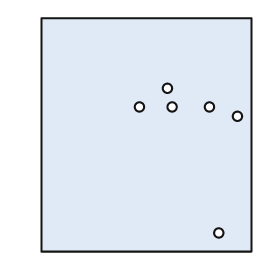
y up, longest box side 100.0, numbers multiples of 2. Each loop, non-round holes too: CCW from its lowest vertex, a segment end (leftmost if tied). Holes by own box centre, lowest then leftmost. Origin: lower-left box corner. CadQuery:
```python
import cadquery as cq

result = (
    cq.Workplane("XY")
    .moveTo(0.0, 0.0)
    .lineTo(90.0, 0.0)
    .lineTo(90.0, 100.0)
    .lineTo(0.0, 100.0)
    .close()
    .moveTo(76.0, 8.0)
    .circle(2.0)
    .moveTo(84.0, 58.0)
    .circle(2.0)
    .moveTo(42.0, 62.0)
    .circle(2.0)
    .moveTo(56.0, 62.0)
    .circle(2.0)
    .moveTo(72.0, 62.0)
    .circle(2.0)
    .moveTo(54.0, 70.0)
    .circle(2.0)
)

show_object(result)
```